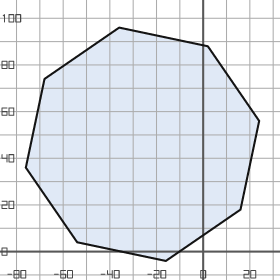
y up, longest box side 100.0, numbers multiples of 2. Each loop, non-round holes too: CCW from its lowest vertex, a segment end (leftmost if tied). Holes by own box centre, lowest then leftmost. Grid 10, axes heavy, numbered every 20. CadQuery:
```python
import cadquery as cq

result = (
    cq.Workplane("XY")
    .moveTo(-16.0, -4.0)
    .lineTo(16.0, 18.0)
    .lineTo(24.0, 56.0)
    .lineTo(2.0, 88.0)
    .lineTo(-36.0, 96.0)
    .lineTo(-68.0, 74.0)
    .lineTo(-76.0, 36.0)
    .lineTo(-54.0, 4.0)
    .close()
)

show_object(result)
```